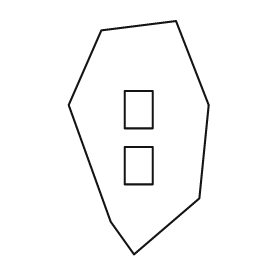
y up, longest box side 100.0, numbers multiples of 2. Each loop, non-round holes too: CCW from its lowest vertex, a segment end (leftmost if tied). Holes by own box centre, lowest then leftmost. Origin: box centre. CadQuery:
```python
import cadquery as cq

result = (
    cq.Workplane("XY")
    .moveTo(-2.0, -50.0)
    .lineTo(26.0, -26.0)
    .lineTo(30.0, 14.0)
    .lineTo(16.0, 50.0)
    .lineTo(-16.0, 46.0)
    .lineTo(-30.0, 14.0)
    .lineTo(-12.0, -36.0)
    .close()
    .moveTo(-6.0, -20.0)
    .lineTo(6.0, -20.0)
    .lineTo(6.0, -4.0)
    .lineTo(-6.0, -4.0)
    .close()
    .moveTo(-6.0, 4.0)
    .lineTo(6.0, 4.0)
    .lineTo(6.0, 20.0)
    .lineTo(-6.0, 20.0)
    .close()
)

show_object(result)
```